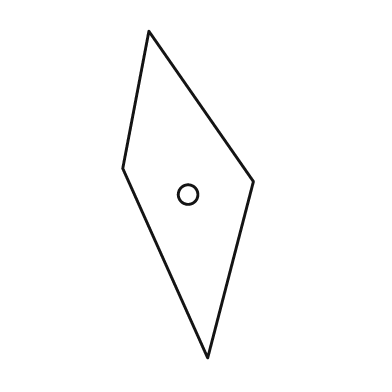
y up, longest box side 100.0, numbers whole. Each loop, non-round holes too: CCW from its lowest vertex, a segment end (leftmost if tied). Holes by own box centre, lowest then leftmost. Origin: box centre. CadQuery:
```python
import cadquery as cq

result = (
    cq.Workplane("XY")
    .moveTo(6.0, -50.0)
    .lineTo(20.0, 4.0)
    .lineTo(-12.0, 50.0)
    .lineTo(-20.0, 8.0)
    .close()
    .moveTo(0.0, 0.0)
    .circle(3.0)
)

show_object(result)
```